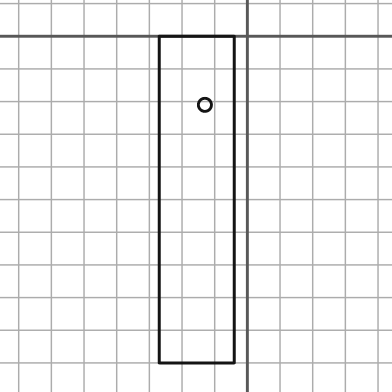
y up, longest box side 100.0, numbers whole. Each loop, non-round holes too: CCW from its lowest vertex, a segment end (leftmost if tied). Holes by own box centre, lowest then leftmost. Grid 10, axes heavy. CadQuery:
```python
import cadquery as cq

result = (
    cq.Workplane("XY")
    .moveTo(-27.0, -100.0)
    .lineTo(-4.0, -100.0)
    .lineTo(-4.0, 0.0)
    .lineTo(-27.0, 0.0)
    .close()
    .moveTo(-13.0, -21.0)
    .circle(2.0)
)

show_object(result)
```